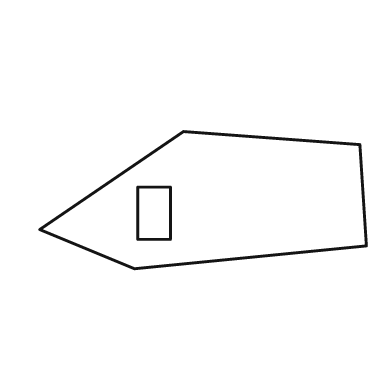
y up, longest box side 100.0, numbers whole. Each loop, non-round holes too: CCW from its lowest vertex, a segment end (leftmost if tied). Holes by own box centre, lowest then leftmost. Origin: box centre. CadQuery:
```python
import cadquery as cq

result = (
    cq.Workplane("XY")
    .moveTo(-21.0, -21.0)
    .lineTo(50.0, -14.0)
    .lineTo(48.0, 17.0)
    .lineTo(-6.0, 21.0)
    .lineTo(-50.0, -9.0)
    .close()
    .moveTo(-20.0, -12.0)
    .lineTo(-10.0, -12.0)
    .lineTo(-10.0, 4.0)
    .lineTo(-20.0, 4.0)
    .close()
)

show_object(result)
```